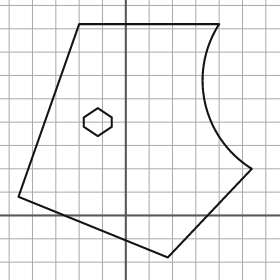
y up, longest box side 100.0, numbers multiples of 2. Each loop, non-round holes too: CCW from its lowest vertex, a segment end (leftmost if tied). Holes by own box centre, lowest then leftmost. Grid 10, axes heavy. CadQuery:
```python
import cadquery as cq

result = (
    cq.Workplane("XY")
    .moveTo(18.0, -18.0)
    .lineTo(54.0, 20.0)
    .threePointArc((34.0, 48.0), (40.0, 82.0))
    .lineTo(-20.0, 82.0)
    .lineTo(-46.0, 8.0)
    .close()
    .moveTo(-12.0, 34.0)
    .lineTo(-6.0, 38.0)
    .lineTo(-6.0, 42.0)
    .lineTo(-12.0, 46.0)
    .lineTo(-18.0, 42.0)
    .lineTo(-18.0, 38.0)
    .close()
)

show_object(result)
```